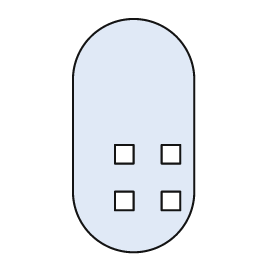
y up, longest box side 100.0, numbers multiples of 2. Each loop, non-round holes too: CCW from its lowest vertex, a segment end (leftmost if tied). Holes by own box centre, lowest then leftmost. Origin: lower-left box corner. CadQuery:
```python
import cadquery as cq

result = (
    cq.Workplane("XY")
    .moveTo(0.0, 26.0)
    .threePointArc((26.0, 0.0), (52.0, 26.0))
    .lineTo(52.0, 74.0)
    .threePointArc((26.0, 100.0), (0.0, 74.0))
    .close()
    .moveTo(18.0, 18.0)
    .lineTo(26.0, 18.0)
    .lineTo(26.0, 26.0)
    .lineTo(18.0, 26.0)
    .close()
    .moveTo(38.0, 18.0)
    .lineTo(46.0, 18.0)
    .lineTo(46.0, 26.0)
    .lineTo(38.0, 26.0)
    .close()
    .moveTo(18.0, 38.0)
    .lineTo(26.0, 38.0)
    .lineTo(26.0, 46.0)
    .lineTo(18.0, 46.0)
    .close()
    .moveTo(38.0, 38.0)
    .lineTo(46.0, 38.0)
    .lineTo(46.0, 46.0)
    .lineTo(38.0, 46.0)
    .close()
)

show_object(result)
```